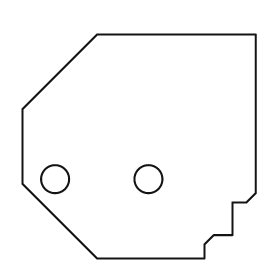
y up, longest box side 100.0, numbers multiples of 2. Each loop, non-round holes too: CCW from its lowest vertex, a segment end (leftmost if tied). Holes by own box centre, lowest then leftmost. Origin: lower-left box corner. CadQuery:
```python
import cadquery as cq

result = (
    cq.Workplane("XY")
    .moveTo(32.0, 0.0)
    .lineTo(78.0, 0.0)
    .lineTo(78.0, 6.0)
    .lineTo(82.0, 10.0)
    .lineTo(90.0, 10.0)
    .lineTo(90.0, 24.0)
    .lineTo(96.0, 24.0)
    .lineTo(100.0, 28.0)
    .lineTo(100.0, 96.0)
    .lineTo(32.0, 96.0)
    .lineTo(0.0, 64.0)
    .lineTo(0.0, 32.0)
    .close()
    .moveTo(14.0, 34.0)
    .circle(6.0)
    .moveTo(54.0, 34.0)
    .circle(6.0)
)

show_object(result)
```